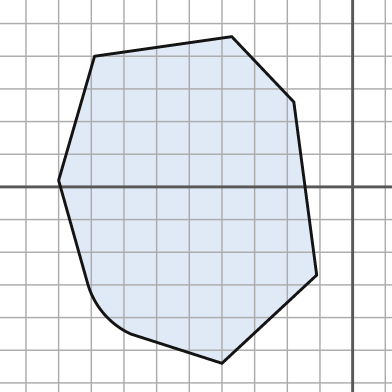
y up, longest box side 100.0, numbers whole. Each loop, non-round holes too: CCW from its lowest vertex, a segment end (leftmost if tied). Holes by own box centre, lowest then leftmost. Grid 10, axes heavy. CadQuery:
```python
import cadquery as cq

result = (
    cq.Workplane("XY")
    .moveTo(-40.0, -54.0)
    .lineTo(-11.0, -27.0)
    .lineTo(-18.0, 26.0)
    .lineTo(-37.0, 46.0)
    .lineTo(-79.0, 40.0)
    .lineTo(-90.0, 2.0)
    .lineTo(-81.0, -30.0)
    .threePointArc((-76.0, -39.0), (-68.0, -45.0))
    .close()
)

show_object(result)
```